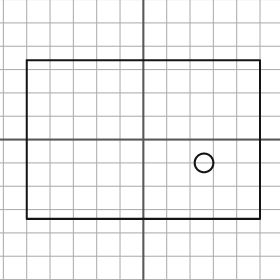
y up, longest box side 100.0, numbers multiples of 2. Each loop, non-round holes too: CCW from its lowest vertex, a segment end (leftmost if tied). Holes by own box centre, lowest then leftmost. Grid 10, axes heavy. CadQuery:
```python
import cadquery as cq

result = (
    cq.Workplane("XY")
    .moveTo(-50.0, -34.0)
    .lineTo(50.0, -34.0)
    .lineTo(50.0, 34.0)
    .lineTo(-50.0, 34.0)
    .close()
    .moveTo(26.0, -10.0)
    .circle(4.0)
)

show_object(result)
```